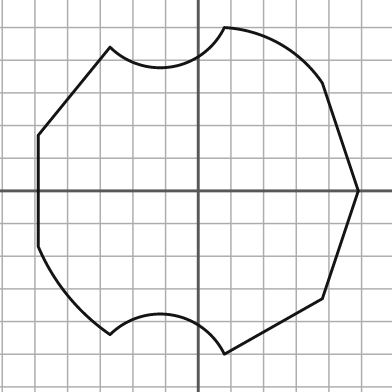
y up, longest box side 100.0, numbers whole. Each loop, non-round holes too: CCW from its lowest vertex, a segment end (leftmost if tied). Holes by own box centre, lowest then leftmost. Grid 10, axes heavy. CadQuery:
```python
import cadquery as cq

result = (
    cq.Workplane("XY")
    .moveTo(8.0, -50.0)
    .lineTo(38.0, -33.0)
    .lineTo(49.0, 0.0)
    .lineTo(38.0, 33.0)
    .threePointArc((25.0, 45.0), (8.0, 50.0))
    .threePointArc((-8.0, 38.0), (-27.0, 44.0))
    .lineTo(-49.0, 17.0)
    .lineTo(-49.0, -17.0)
    .threePointArc((-40.0, -32.0), (-27.0, -44.0))
    .threePointArc((-8.0, -38.0), (8.0, -50.0))
    .close()
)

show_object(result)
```